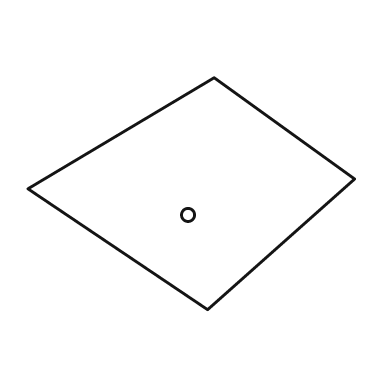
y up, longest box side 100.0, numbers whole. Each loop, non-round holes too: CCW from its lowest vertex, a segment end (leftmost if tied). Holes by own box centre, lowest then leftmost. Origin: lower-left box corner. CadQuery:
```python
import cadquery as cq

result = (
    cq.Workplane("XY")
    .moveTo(55.0, 0.0)
    .lineTo(100.0, 40.0)
    .lineTo(57.0, 71.0)
    .lineTo(0.0, 37.0)
    .close()
    .moveTo(49.0, 29.0)
    .circle(2.0)
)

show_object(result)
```